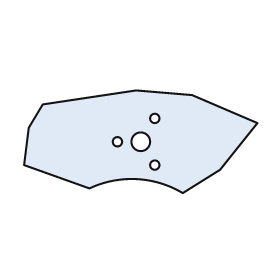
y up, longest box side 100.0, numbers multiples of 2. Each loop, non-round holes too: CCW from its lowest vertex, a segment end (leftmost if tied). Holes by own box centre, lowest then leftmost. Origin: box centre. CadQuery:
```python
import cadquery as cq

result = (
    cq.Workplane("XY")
    .moveTo(18.0, -22.0)
    .lineTo(34.0, -12.0)
    .lineTo(50.0, 8.0)
    .lineTo(22.0, 20.0)
    .lineTo(-2.0, 22.0)
    .lineTo(-42.0, 16.0)
    .lineTo(-48.0, 6.0)
    .lineTo(-50.0, -10.0)
    .lineTo(-22.0, -20.0)
    .threePointArc((-2.0, -16.0), (18.0, -22.0))
    .close()
    .moveTo(6.0, -10.0)
    .circle(2.0)
    .moveTo(-10.0, 0.0)
    .circle(2.0)
    .moveTo(0.0, 0.0)
    .circle(4.0)
    .moveTo(6.0, 10.0)
    .circle(2.0)
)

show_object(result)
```